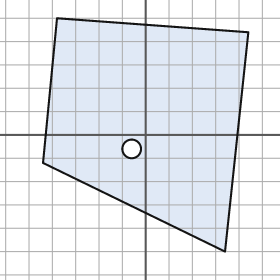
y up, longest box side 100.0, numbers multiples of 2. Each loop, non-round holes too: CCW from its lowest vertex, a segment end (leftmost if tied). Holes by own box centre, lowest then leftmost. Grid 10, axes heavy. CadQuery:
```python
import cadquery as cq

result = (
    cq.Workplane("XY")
    .moveTo(34.0, -50.0)
    .lineTo(44.0, 44.0)
    .lineTo(-38.0, 50.0)
    .lineTo(-44.0, -12.0)
    .close()
    .moveTo(-6.0, -6.0)
    .circle(4.0)
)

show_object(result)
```